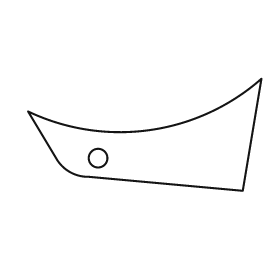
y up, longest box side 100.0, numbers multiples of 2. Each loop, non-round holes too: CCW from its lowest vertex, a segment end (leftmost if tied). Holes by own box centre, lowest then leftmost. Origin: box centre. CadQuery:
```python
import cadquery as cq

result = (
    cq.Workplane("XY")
    .moveTo(42.0, -24.0)
    .lineTo(50.0, 24.0)
    .threePointArc((2.0, 2.0), (-50.0, 10.0))
    .lineTo(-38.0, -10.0)
    .threePointArc((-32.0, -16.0), (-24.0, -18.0))
    .close()
    .moveTo(-20.0, -10.0)
    .circle(4.0)
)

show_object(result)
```